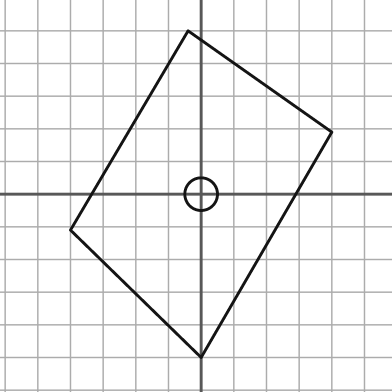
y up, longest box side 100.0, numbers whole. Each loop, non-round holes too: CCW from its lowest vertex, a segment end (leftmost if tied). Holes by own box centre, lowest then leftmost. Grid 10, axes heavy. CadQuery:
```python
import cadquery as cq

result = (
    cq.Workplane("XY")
    .moveTo(0.0, -50.0)
    .lineTo(40.0, 19.0)
    .lineTo(-4.0, 50.0)
    .lineTo(-40.0, -11.0)
    .close()
    .moveTo(0.0, 0.0)
    .circle(5.0)
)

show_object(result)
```